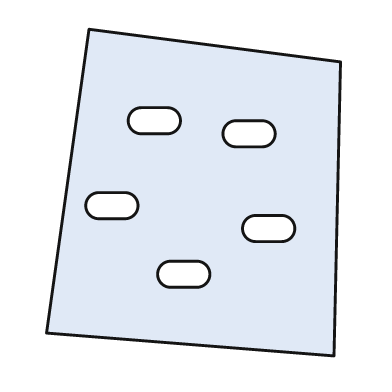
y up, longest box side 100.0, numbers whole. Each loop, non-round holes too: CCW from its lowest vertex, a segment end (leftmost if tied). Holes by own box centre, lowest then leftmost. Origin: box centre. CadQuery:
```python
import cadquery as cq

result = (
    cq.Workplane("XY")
    .moveTo(43.0, -50.0)
    .lineTo(45.0, 40.0)
    .lineTo(-32.0, 50.0)
    .lineTo(-45.0, -43.0)
    .close()
    .moveTo(-7.0, -29.0)
    .lineTo(1.0, -29.0)
    .threePointArc((5.0, -25.0), (1.0, -21.0))
    .lineTo(-7.0, -21.0)
    .threePointArc((-11.0, -25.0), (-7.0, -29.0))
    .close()
    .moveTo(19.0, -15.0)
    .lineTo(27.0, -15.0)
    .threePointArc((31.0, -11.0), (27.0, -7.0))
    .lineTo(19.0, -7.0)
    .threePointArc((15.0, -11.0), (19.0, -15.0))
    .close()
    .moveTo(-29.0, -8.0)
    .lineTo(-21.0, -8.0)
    .threePointArc((-17.0, -4.0), (-21.0, 0.0))
    .lineTo(-29.0, 0.0)
    .threePointArc((-33.0, -4.0), (-29.0, -8.0))
    .close()
    .moveTo(13.0, 14.0)
    .lineTo(21.0, 14.0)
    .threePointArc((25.0, 18.0), (21.0, 22.0))
    .lineTo(13.0, 22.0)
    .threePointArc((9.0, 18.0), (13.0, 14.0))
    .close()
    .moveTo(-16.0, 18.0)
    .lineTo(-8.0, 18.0)
    .threePointArc((-4.0, 22.0), (-8.0, 26.0))
    .lineTo(-16.0, 26.0)
    .threePointArc((-20.0, 22.0), (-16.0, 18.0))
    .close()
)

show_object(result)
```